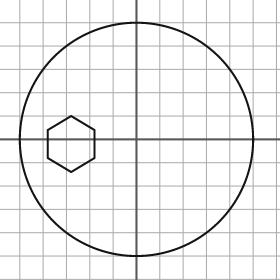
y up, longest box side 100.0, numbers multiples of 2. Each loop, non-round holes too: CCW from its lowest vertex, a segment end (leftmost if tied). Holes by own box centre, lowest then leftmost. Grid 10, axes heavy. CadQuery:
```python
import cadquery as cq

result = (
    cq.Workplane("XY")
    .moveTo(0.0, 0.0)
    .circle(50.0)
    .moveTo(-28.0, -14.0)
    .lineTo(-18.0, -8.0)
    .lineTo(-18.0, 4.0)
    .lineTo(-28.0, 10.0)
    .lineTo(-38.0, 4.0)
    .lineTo(-38.0, -8.0)
    .close()
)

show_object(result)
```